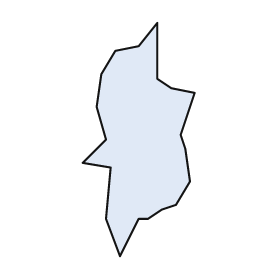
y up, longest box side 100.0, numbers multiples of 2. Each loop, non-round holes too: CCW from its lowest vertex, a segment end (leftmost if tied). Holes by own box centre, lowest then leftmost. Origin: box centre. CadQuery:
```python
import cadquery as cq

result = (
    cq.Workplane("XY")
    .moveTo(-8.0, -50.0)
    .lineTo(0.0, -34.0)
    .lineTo(4.0, -34.0)
    .lineTo(10.0, -30.0)
    .lineTo(16.0, -28.0)
    .lineTo(22.0, -18.0)
    .lineTo(20.0, -4.0)
    .lineTo(18.0, 2.0)
    .lineTo(24.0, 20.0)
    .lineTo(14.0, 22.0)
    .lineTo(8.0, 26.0)
    .lineTo(8.0, 50.0)
    .lineTo(0.0, 40.0)
    .lineTo(-10.0, 38.0)
    .lineTo(-16.0, 28.0)
    .lineTo(-18.0, 14.0)
    .lineTo(-14.0, 0.0)
    .lineTo(-24.0, -10.0)
    .lineTo(-12.0, -12.0)
    .lineTo(-14.0, -34.0)
    .close()
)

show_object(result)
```